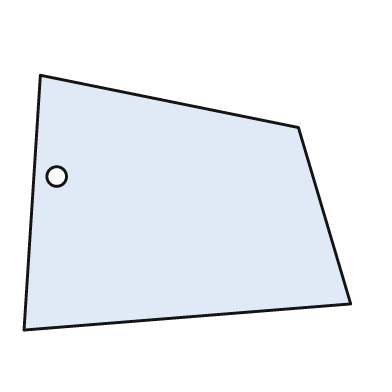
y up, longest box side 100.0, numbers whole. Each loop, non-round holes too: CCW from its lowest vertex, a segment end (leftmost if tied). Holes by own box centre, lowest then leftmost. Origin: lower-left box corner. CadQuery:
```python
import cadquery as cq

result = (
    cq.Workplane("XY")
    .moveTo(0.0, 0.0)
    .lineTo(100.0, 8.0)
    .lineTo(84.0, 62.0)
    .lineTo(5.0, 78.0)
    .close()
    .moveTo(10.0, 47.0)
    .circle(3.0)
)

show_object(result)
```